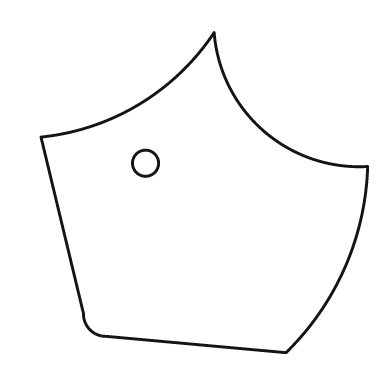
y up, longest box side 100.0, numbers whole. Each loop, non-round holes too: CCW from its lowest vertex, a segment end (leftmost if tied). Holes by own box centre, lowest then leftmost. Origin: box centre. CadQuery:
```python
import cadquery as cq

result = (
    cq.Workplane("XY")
    .moveTo(25.0, -49.0)
    .threePointArc((43.0, -23.0), (50.0, 8.0))
    .threePointArc((18.0, 19.0), (3.0, 49.0))
    .threePointArc((-20.0, 27.0), (-50.0, 17.0))
    .lineTo(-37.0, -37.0)
    .threePointArc((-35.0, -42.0), (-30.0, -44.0))
    .close()
    .moveTo(-18.0, 9.0)
    .circle(4.0)
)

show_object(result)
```